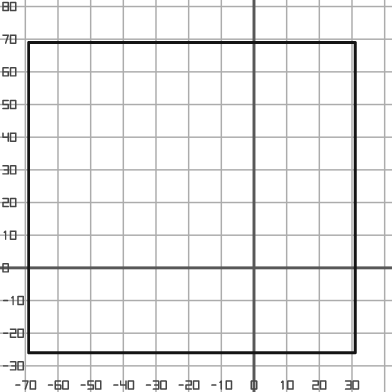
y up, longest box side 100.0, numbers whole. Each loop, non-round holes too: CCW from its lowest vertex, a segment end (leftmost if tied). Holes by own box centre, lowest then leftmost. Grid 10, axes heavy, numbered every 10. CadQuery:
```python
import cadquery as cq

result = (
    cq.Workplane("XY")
    .moveTo(-69.0, -26.0)
    .lineTo(31.0, -26.0)
    .lineTo(31.0, 69.0)
    .lineTo(-69.0, 69.0)
    .close()
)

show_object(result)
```